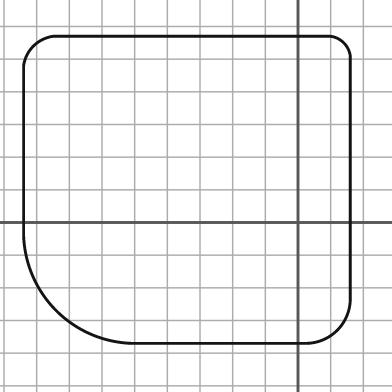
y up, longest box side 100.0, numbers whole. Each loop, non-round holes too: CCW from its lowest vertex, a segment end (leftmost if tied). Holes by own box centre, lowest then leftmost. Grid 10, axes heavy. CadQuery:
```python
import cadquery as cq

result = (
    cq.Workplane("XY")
    .moveTo(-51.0, -37.0)
    .lineTo(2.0, -37.0)
    .threePointArc((12.0, -33.0), (16.0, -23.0))
    .lineTo(16.0, 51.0)
    .threePointArc((14.0, 55.0), (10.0, 57.0))
    .lineTo(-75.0, 57.0)
    .threePointArc((-81.0, 54.0), (-84.0, 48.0))
    .lineTo(-84.0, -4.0)
    .threePointArc((-74.0, -27.0), (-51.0, -37.0))
    .close()
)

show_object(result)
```